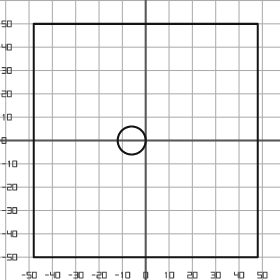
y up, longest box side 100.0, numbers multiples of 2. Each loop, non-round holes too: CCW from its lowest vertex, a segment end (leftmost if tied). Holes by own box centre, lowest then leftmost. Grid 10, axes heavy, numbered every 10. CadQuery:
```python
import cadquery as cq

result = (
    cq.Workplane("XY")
    .moveTo(-48.0, -50.0)
    .lineTo(48.0, -50.0)
    .lineTo(48.0, 50.0)
    .lineTo(-48.0, 50.0)
    .close()
    .moveTo(-6.0, 0.0)
    .circle(6.0)
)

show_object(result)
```